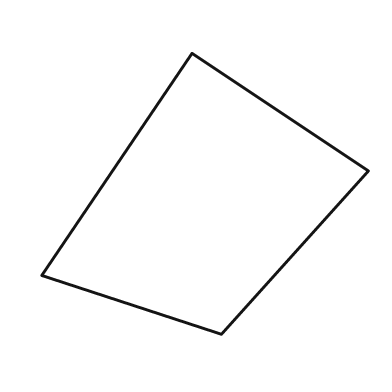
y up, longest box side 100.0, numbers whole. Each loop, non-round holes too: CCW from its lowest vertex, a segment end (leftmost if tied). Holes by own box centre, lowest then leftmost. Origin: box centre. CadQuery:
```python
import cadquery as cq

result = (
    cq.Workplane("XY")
    .moveTo(5.0, -43.0)
    .lineTo(50.0, 7.0)
    .lineTo(-4.0, 43.0)
    .lineTo(-50.0, -25.0)
    .close()
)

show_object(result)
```